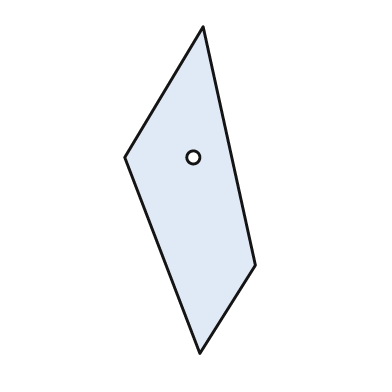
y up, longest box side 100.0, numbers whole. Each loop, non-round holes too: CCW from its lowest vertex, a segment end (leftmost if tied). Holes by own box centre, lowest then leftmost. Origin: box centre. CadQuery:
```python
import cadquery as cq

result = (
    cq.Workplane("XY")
    .moveTo(3.0, -50.0)
    .lineTo(20.0, -23.0)
    .lineTo(4.0, 50.0)
    .lineTo(-20.0, 10.0)
    .close()
    .moveTo(1.0, 10.0)
    .circle(2.0)
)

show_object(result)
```